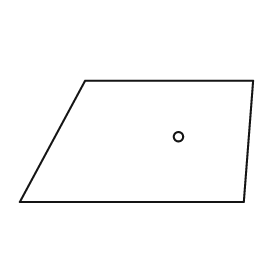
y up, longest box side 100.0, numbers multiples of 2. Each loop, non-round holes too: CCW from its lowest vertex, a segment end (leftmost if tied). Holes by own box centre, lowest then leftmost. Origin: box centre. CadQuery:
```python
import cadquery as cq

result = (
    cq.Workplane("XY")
    .moveTo(-50.0, -26.0)
    .lineTo(46.0, -26.0)
    .lineTo(50.0, 26.0)
    .lineTo(-22.0, 26.0)
    .close()
    .moveTo(18.0, 2.0)
    .circle(2.0)
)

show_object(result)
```